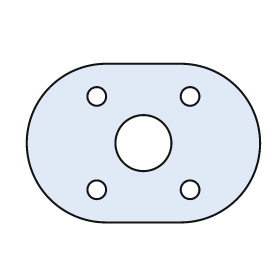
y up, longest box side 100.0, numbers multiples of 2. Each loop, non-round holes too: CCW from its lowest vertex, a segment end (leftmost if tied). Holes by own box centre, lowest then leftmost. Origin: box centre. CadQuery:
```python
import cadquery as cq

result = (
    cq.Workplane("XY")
    .moveTo(-16.0, -34.0)
    .lineTo(16.0, -34.0)
    .threePointArc((50.0, 0.0), (16.0, 34.0))
    .lineTo(-16.0, 34.0)
    .threePointArc((-50.0, 0.0), (-16.0, -34.0))
    .close()
    .moveTo(-20.0, -20.0)
    .circle(4.0)
    .moveTo(20.0, -20.0)
    .circle(4.0)
    .moveTo(0.0, 0.0)
    .circle(12.0)
    .moveTo(-20.0, 20.0)
    .circle(4.0)
    .moveTo(20.0, 20.0)
    .circle(4.0)
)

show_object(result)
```